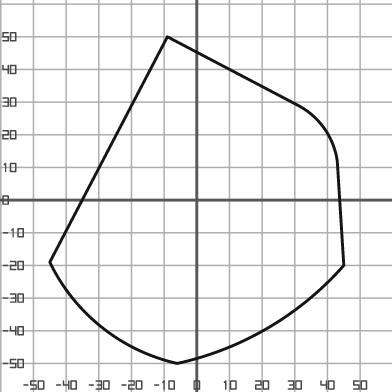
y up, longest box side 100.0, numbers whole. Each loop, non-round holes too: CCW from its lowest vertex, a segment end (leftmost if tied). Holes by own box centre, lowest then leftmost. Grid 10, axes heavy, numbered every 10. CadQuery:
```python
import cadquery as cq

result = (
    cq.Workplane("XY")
    .moveTo(-6.0, -50.0)
    .threePointArc((22.0, -39.0), (45.0, -20.0))
    .lineTo(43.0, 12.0)
    .threePointArc((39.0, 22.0), (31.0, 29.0))
    .lineTo(-9.0, 50.0)
    .lineTo(-45.0, -19.0)
    .threePointArc((-29.0, -39.0), (-6.0, -50.0))
    .close()
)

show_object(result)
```